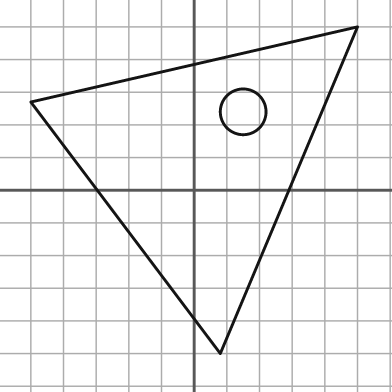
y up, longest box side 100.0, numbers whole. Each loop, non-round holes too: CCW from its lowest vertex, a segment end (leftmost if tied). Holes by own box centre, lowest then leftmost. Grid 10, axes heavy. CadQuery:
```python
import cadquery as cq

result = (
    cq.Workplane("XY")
    .moveTo(8.0, -50.0)
    .lineTo(50.0, 50.0)
    .lineTo(-50.0, 27.0)
    .close()
    .moveTo(15.0, 24.0)
    .circle(7.0)
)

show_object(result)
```